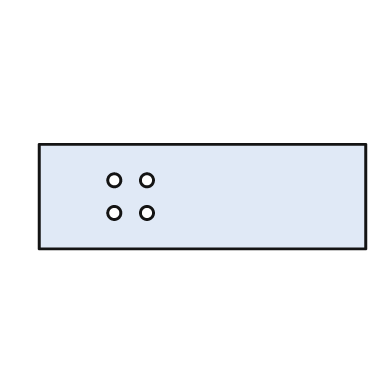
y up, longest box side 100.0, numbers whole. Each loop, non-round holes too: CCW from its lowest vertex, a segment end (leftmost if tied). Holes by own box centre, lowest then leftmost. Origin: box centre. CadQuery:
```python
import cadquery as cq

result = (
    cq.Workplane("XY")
    .moveTo(-50.0, -16.0)
    .lineTo(50.0, -16.0)
    .lineTo(50.0, 16.0)
    .lineTo(-50.0, 16.0)
    .close()
    .moveTo(-27.0, -5.0)
    .circle(2.0)
    .moveTo(-17.0, -5.0)
    .circle(2.0)
    .moveTo(-27.0, 5.0)
    .circle(2.0)
    .moveTo(-17.0, 5.0)
    .circle(2.0)
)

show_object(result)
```